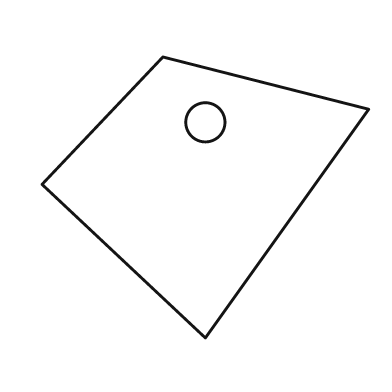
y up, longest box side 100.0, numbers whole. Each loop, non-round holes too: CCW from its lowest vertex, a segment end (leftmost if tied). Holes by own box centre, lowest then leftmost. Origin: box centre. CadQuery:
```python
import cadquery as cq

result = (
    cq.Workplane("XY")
    .moveTo(0.0, -43.0)
    .lineTo(50.0, 27.0)
    .lineTo(-13.0, 43.0)
    .lineTo(-50.0, 4.0)
    .close()
    .moveTo(0.0, 23.0)
    .circle(6.0)
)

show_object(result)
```